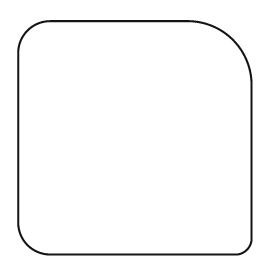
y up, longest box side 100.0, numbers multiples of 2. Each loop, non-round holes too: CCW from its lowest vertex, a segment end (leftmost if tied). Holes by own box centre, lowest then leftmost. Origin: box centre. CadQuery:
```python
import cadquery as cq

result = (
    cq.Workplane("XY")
    .moveTo(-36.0, -50.0)
    .lineTo(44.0, -50.0)
    .threePointArc((48.0, -48.0), (50.0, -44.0))
    .lineTo(50.0, 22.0)
    .threePointArc((42.0, 42.0), (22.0, 50.0))
    .lineTo(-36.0, 50.0)
    .threePointArc((-46.0, 46.0), (-50.0, 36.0))
    .lineTo(-50.0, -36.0)
    .threePointArc((-46.0, -46.0), (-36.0, -50.0))
    .close()
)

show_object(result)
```